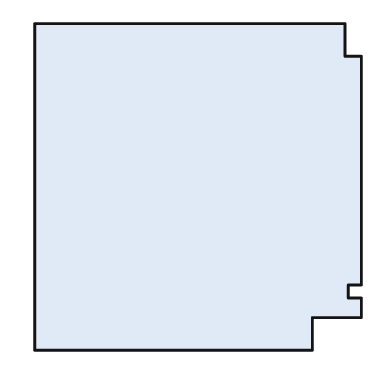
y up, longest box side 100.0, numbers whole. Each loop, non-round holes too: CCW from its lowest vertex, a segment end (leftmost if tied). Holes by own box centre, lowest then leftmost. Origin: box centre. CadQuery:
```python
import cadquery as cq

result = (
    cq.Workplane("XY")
    .moveTo(-50.0, -50.0)
    .lineTo(35.0, -50.0)
    .lineTo(35.0, -40.0)
    .lineTo(50.0, -40.0)
    .lineTo(50.0, -34.0)
    .lineTo(46.0, -34.0)
    .lineTo(46.0, -30.0)
    .lineTo(50.0, -30.0)
    .lineTo(50.0, 40.0)
    .lineTo(45.0, 40.0)
    .lineTo(45.0, 50.0)
    .lineTo(-50.0, 50.0)
    .close()
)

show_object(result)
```